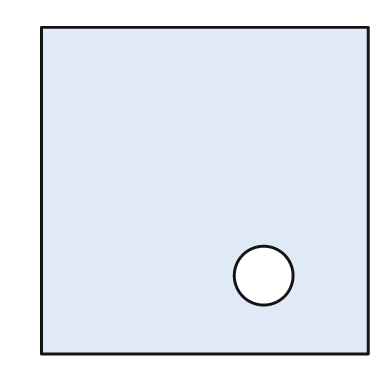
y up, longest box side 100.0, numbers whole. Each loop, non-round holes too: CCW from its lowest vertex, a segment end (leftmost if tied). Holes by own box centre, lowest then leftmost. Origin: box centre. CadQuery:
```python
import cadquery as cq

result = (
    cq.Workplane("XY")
    .moveTo(-50.0, -50.0)
    .lineTo(50.0, -50.0)
    .lineTo(50.0, 50.0)
    .lineTo(-50.0, 50.0)
    .close()
    .moveTo(18.0, -26.0)
    .circle(9.0)
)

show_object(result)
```